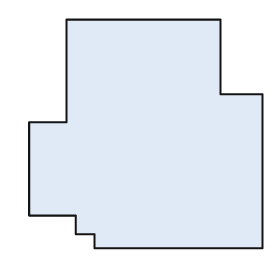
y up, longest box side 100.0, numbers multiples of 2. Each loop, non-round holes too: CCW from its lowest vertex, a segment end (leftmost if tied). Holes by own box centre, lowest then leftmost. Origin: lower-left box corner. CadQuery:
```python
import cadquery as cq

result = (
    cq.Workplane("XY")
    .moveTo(28.0, 0.0)
    .lineTo(100.0, 0.0)
    .lineTo(100.0, 66.0)
    .lineTo(82.0, 66.0)
    .lineTo(82.0, 98.0)
    .lineTo(16.0, 98.0)
    .lineTo(16.0, 54.0)
    .lineTo(0.0, 54.0)
    .lineTo(0.0, 14.0)
    .lineTo(20.0, 14.0)
    .lineTo(20.0, 6.0)
    .lineTo(28.0, 6.0)
    .close()
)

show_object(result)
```